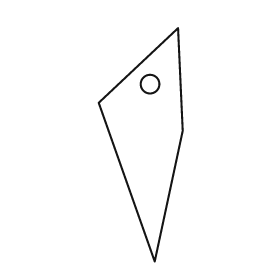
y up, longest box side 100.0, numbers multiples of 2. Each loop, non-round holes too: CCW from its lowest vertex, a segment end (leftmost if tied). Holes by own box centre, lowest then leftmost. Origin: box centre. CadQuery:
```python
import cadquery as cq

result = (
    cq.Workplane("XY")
    .moveTo(6.0, -50.0)
    .lineTo(18.0, 6.0)
    .lineTo(16.0, 50.0)
    .lineTo(-18.0, 18.0)
    .close()
    .moveTo(4.0, 26.0)
    .circle(4.0)
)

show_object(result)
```